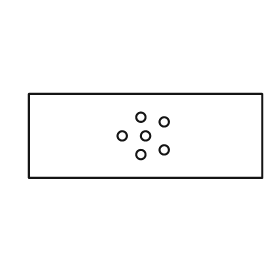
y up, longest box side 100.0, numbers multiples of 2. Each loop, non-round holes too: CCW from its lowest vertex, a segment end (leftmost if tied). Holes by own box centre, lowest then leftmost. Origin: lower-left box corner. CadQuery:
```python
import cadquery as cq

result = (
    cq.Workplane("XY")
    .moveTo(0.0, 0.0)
    .lineTo(100.0, 0.0)
    .lineTo(100.0, 36.0)
    .lineTo(0.0, 36.0)
    .close()
    .moveTo(48.0, 10.0)
    .circle(2.0)
    .moveTo(58.0, 12.0)
    .circle(2.0)
    .moveTo(40.0, 18.0)
    .circle(2.0)
    .moveTo(50.0, 18.0)
    .circle(2.0)
    .moveTo(58.0, 24.0)
    .circle(2.0)
    .moveTo(48.0, 26.0)
    .circle(2.0)
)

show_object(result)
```